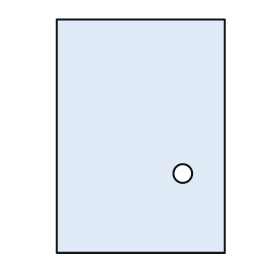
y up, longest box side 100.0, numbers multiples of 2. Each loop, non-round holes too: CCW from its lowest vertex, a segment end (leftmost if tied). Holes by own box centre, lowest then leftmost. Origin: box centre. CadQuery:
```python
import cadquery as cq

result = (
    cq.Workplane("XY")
    .moveTo(-36.0, -50.0)
    .lineTo(36.0, -50.0)
    .lineTo(36.0, 50.0)
    .lineTo(-36.0, 50.0)
    .close()
    .moveTo(18.0, -16.0)
    .circle(4.0)
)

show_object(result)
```